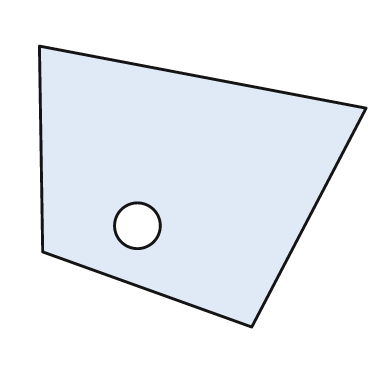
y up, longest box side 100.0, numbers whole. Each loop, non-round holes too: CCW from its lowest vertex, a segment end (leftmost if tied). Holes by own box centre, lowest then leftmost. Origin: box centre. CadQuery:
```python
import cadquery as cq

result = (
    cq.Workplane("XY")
    .moveTo(15.0, -43.0)
    .lineTo(50.0, 24.0)
    .lineTo(-50.0, 43.0)
    .lineTo(-49.0, -20.0)
    .close()
    .moveTo(-20.0, -12.0)
    .circle(7.0)
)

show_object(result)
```